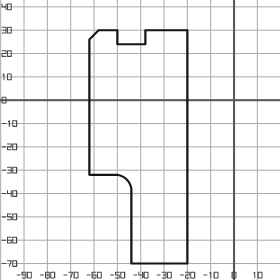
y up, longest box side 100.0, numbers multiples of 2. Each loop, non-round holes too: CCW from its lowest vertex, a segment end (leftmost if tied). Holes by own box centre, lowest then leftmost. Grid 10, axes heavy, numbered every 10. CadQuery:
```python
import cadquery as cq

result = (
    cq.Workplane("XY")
    .moveTo(-44.0, -70.0)
    .lineTo(-20.0, -70.0)
    .lineTo(-20.0, 30.0)
    .lineTo(-38.0, 30.0)
    .lineTo(-38.0, 24.0)
    .lineTo(-50.0, 24.0)
    .lineTo(-50.0, 30.0)
    .lineTo(-58.0, 30.0)
    .lineTo(-62.0, 26.0)
    .lineTo(-62.0, -32.0)
    .lineTo(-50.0, -32.0)
    .threePointArc((-46.0, -34.0), (-44.0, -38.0))
    .close()
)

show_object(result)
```